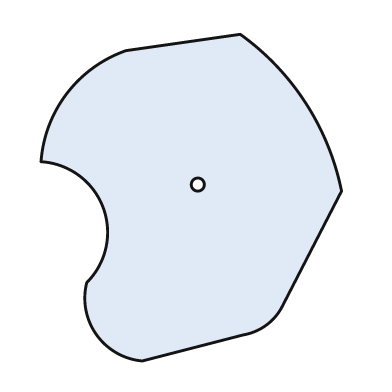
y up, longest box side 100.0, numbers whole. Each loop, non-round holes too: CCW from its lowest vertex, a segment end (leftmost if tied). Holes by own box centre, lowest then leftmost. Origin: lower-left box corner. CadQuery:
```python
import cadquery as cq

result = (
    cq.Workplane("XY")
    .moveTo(31.0, 0.0)
    .lineTo(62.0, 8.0)
    .threePointArc((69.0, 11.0), (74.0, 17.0))
    .lineTo(92.0, 52.0)
    .threePointArc((81.0, 79.0), (61.0, 100.0))
    .lineTo(26.0, 95.0)
    .threePointArc((8.0, 82.0), (0.0, 61.0))
    .threePointArc((19.0, 47.0), (14.0, 24.0))
    .threePointArc((17.0, 8.0), (31.0, 0.0))
    .close()
    .moveTo(48.0, 54.0)
    .circle(2.0)
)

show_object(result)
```